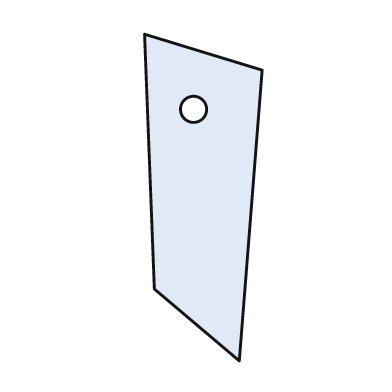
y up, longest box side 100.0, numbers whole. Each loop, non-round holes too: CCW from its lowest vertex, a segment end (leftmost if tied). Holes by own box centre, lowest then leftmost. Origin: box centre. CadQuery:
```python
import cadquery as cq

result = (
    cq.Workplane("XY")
    .moveTo(11.0, -50.0)
    .lineTo(18.0, 39.0)
    .lineTo(-18.0, 50.0)
    .lineTo(-15.0, -28.0)
    .close()
    .moveTo(-3.0, 27.0)
    .circle(4.0)
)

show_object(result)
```